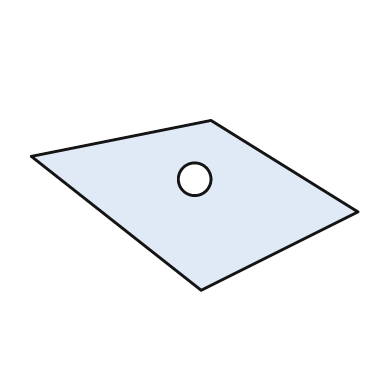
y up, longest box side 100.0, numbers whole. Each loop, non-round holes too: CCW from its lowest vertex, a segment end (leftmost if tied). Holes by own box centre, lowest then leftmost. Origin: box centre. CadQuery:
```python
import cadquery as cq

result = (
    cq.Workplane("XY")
    .moveTo(2.0, -26.0)
    .lineTo(50.0, -2.0)
    .lineTo(5.0, 26.0)
    .lineTo(-50.0, 15.0)
    .close()
    .moveTo(0.0, 8.0)
    .circle(5.0)
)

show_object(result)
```